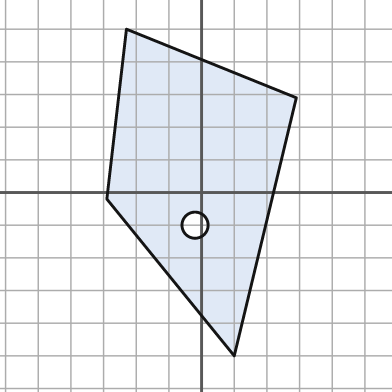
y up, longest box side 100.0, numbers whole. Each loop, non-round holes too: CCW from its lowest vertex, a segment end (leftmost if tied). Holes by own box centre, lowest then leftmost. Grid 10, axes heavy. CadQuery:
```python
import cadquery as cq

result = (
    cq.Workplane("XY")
    .moveTo(10.0, -50.0)
    .lineTo(29.0, 29.0)
    .lineTo(-23.0, 50.0)
    .lineTo(-29.0, -2.0)
    .close()
    .moveTo(-2.0, -10.0)
    .circle(4.0)
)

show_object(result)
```